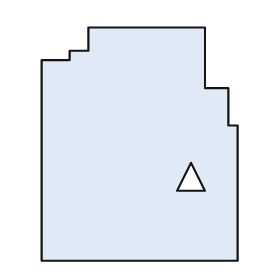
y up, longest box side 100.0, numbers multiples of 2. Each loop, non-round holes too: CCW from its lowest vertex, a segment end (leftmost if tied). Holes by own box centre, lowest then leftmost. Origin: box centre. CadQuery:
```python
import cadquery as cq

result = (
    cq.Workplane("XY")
    .moveTo(-42.0, -50.0)
    .lineTo(42.0, -50.0)
    .lineTo(42.0, 8.0)
    .lineTo(38.0, 8.0)
    .lineTo(38.0, 24.0)
    .lineTo(28.0, 24.0)
    .lineTo(28.0, 50.0)
    .lineTo(-22.0, 50.0)
    .lineTo(-22.0, 40.0)
    .lineTo(-30.0, 40.0)
    .lineTo(-30.0, 36.0)
    .lineTo(-42.0, 36.0)
    .close()
    .moveTo(16.0, -20.0)
    .lineTo(28.0, -20.0)
    .lineTo(22.0, -8.0)
    .close()
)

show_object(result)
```